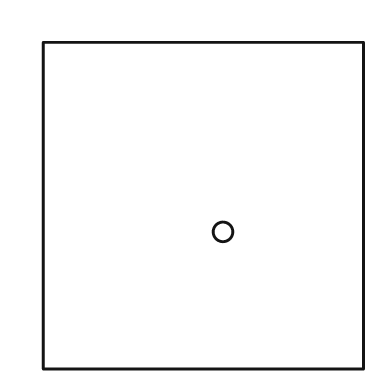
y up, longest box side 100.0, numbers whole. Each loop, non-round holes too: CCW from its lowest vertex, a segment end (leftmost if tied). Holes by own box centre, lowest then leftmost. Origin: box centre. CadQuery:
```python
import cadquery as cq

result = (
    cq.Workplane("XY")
    .moveTo(-49.0, -50.0)
    .lineTo(49.0, -50.0)
    .lineTo(49.0, 50.0)
    .lineTo(-49.0, 50.0)
    .close()
    .moveTo(6.0, -8.0)
    .circle(3.0)
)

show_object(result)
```